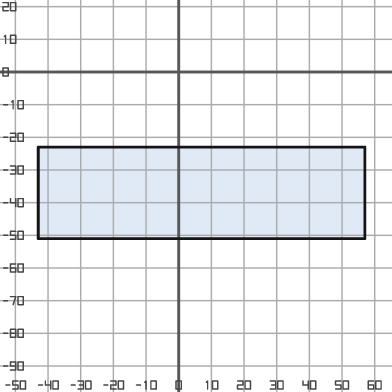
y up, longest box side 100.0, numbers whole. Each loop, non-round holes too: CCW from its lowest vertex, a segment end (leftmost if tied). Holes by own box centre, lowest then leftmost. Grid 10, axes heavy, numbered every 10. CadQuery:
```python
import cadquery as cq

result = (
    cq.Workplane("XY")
    .moveTo(-43.0, -51.0)
    .lineTo(57.0, -51.0)
    .lineTo(57.0, -23.0)
    .lineTo(-43.0, -23.0)
    .close()
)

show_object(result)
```